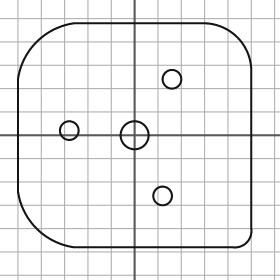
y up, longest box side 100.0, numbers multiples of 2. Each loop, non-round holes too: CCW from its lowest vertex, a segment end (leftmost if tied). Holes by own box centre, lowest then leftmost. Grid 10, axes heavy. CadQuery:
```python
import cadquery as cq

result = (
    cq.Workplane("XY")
    .moveTo(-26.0, -48.0)
    .lineTo(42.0, -48.0)
    .threePointArc((48.0, -46.0), (50.0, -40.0))
    .lineTo(50.0, 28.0)
    .threePointArc((44.0, 42.0), (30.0, 48.0))
    .lineTo(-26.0, 48.0)
    .threePointArc((-42.0, 40.0), (-50.0, 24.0))
    .lineTo(-50.0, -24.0)
    .threePointArc((-42.0, -40.0), (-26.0, -48.0))
    .close()
    .moveTo(12.0, -26.0)
    .circle(4.0)
    .moveTo(0.0, 0.0)
    .circle(6.0)
    .moveTo(-28.0, 2.0)
    .circle(4.0)
    .moveTo(16.0, 24.0)
    .circle(4.0)
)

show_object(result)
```